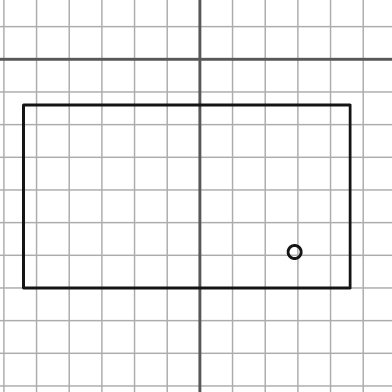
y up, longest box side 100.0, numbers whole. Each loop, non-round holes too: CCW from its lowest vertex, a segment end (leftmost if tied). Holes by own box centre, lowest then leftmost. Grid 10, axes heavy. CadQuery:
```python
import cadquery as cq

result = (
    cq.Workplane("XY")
    .moveTo(-54.0, -70.0)
    .lineTo(46.0, -70.0)
    .lineTo(46.0, -14.0)
    .lineTo(-54.0, -14.0)
    .close()
    .moveTo(29.0, -59.0)
    .circle(2.0)
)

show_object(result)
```